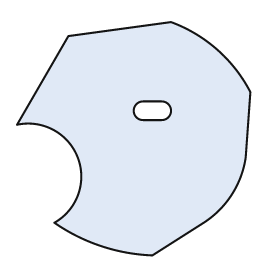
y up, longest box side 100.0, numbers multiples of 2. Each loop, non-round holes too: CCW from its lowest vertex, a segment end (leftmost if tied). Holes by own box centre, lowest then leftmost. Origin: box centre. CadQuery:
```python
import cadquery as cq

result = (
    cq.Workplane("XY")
    .moveTo(8.0, -50.0)
    .lineTo(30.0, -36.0)
    .threePointArc((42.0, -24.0), (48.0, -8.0))
    .lineTo(50.0, 20.0)
    .threePointArc((36.0, 38.0), (16.0, 50.0))
    .lineTo(-28.0, 44.0)
    .lineTo(-50.0, 6.0)
    .threePointArc((-24.0, -8.0), (-34.0, -36.0))
    .threePointArc((-14.0, -46.0), (8.0, -50.0))
    .close()
    .moveTo(4.0, 8.0)
    .lineTo(12.0, 8.0)
    .threePointArc((16.0, 12.0), (12.0, 16.0))
    .lineTo(4.0, 16.0)
    .threePointArc((0.0, 12.0), (4.0, 8.0))
    .close()
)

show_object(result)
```